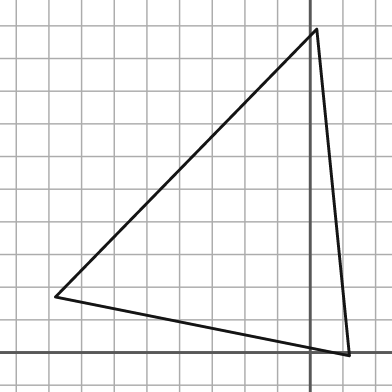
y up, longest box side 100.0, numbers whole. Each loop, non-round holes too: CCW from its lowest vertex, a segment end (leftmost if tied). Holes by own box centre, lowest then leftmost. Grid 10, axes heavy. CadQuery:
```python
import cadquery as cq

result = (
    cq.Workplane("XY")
    .moveTo(12.0, -1.0)
    .lineTo(2.0, 99.0)
    .lineTo(-78.0, 17.0)
    .close()
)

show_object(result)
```